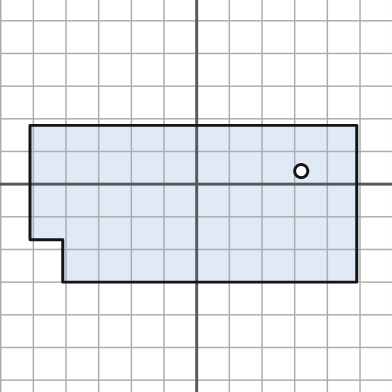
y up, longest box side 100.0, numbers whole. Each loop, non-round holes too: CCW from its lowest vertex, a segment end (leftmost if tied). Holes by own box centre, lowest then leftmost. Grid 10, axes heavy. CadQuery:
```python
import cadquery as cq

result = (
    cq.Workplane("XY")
    .moveTo(-41.0, -30.0)
    .lineTo(49.0, -30.0)
    .lineTo(49.0, 18.0)
    .lineTo(-51.0, 18.0)
    .lineTo(-51.0, -17.0)
    .lineTo(-41.0, -17.0)
    .close()
    .moveTo(32.0, 4.0)
    .circle(2.0)
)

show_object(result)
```